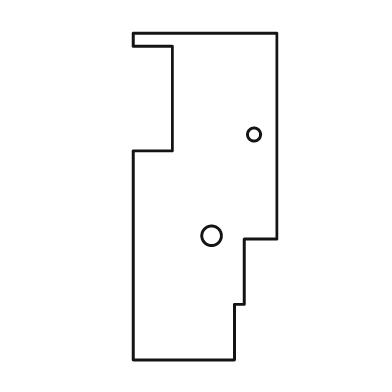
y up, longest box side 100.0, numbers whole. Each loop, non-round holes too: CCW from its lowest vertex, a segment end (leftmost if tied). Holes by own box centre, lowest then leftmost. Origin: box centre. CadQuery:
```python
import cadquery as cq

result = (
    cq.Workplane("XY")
    .moveTo(-22.0, -50.0)
    .lineTo(9.0, -50.0)
    .lineTo(9.0, -33.0)
    .lineTo(12.0, -33.0)
    .lineTo(12.0, -13.0)
    .lineTo(22.0, -13.0)
    .lineTo(22.0, 50.0)
    .lineTo(-22.0, 50.0)
    .lineTo(-22.0, 46.0)
    .lineTo(-10.0, 46.0)
    .lineTo(-10.0, 14.0)
    .lineTo(-22.0, 14.0)
    .close()
    .moveTo(2.0, -12.0)
    .circle(3.0)
    .moveTo(15.0, 19.0)
    .circle(2.0)
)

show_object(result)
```